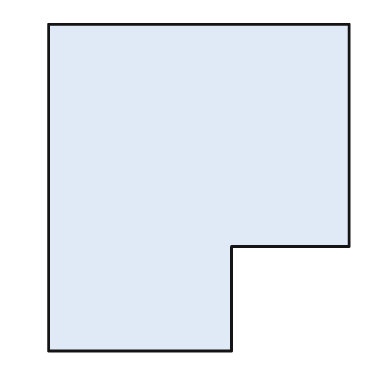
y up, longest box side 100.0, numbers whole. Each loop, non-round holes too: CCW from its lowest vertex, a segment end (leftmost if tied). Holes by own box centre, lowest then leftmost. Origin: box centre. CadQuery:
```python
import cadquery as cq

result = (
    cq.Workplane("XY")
    .moveTo(-46.0, -50.0)
    .lineTo(10.0, -50.0)
    .lineTo(10.0, -18.0)
    .lineTo(46.0, -18.0)
    .lineTo(46.0, 50.0)
    .lineTo(-46.0, 50.0)
    .close()
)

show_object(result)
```